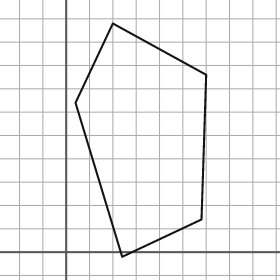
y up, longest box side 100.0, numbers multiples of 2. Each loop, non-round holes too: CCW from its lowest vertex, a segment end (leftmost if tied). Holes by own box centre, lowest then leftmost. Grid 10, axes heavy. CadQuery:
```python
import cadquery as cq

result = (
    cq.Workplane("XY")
    .moveTo(24.0, -2.0)
    .lineTo(58.0, 14.0)
    .lineTo(60.0, 76.0)
    .lineTo(20.0, 98.0)
    .lineTo(4.0, 64.0)
    .close()
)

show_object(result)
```